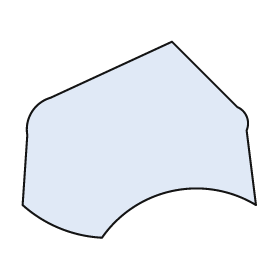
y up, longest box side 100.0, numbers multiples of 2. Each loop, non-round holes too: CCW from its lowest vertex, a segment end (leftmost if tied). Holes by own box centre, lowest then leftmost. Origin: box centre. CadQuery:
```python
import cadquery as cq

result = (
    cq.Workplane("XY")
    .moveTo(-16.0, -42.0)
    .threePointArc((14.0, -22.0), (50.0, -28.0))
    .lineTo(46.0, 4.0)
    .threePointArc((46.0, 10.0), (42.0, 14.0))
    .lineTo(14.0, 42.0)
    .lineTo(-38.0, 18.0)
    .threePointArc((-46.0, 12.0), (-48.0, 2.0))
    .lineTo(-50.0, -28.0)
    .threePointArc((-34.0, -38.0), (-16.0, -42.0))
    .close()
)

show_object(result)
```